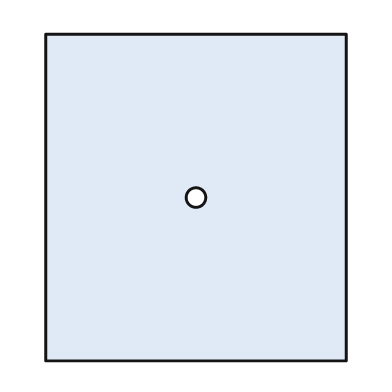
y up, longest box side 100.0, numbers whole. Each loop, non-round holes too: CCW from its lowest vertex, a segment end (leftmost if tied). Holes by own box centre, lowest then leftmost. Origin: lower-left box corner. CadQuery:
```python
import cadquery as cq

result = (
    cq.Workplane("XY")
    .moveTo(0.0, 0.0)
    .lineTo(92.0, 0.0)
    .lineTo(92.0, 100.0)
    .lineTo(0.0, 100.0)
    .close()
    .moveTo(46.0, 50.0)
    .circle(3.0)
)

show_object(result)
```